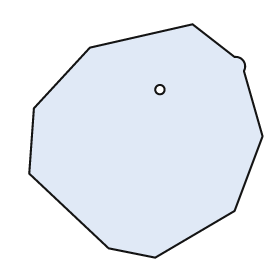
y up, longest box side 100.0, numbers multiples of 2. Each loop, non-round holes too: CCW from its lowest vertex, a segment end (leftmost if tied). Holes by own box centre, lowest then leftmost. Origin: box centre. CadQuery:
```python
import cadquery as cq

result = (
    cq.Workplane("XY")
    .moveTo(4.0, -50.0)
    .lineTo(38.0, -30.0)
    .lineTo(50.0, 2.0)
    .lineTo(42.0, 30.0)
    .threePointArc((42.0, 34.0), (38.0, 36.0))
    .lineTo(20.0, 50.0)
    .lineTo(-24.0, 40.0)
    .lineTo(-48.0, 14.0)
    .lineTo(-50.0, -14.0)
    .lineTo(-16.0, -46.0)
    .close()
    .moveTo(6.0, 22.0)
    .circle(2.0)
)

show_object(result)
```